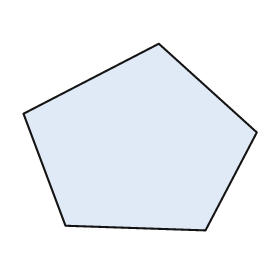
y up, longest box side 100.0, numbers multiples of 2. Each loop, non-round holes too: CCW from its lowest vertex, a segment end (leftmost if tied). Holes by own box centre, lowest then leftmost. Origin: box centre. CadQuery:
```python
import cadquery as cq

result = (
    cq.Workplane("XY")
    .moveTo(28.0, -40.0)
    .lineTo(50.0, 2.0)
    .lineTo(8.0, 40.0)
    .lineTo(-50.0, 10.0)
    .lineTo(-32.0, -38.0)
    .close()
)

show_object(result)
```